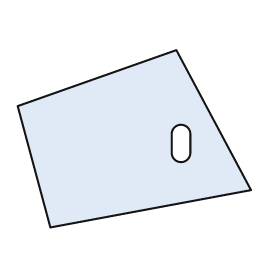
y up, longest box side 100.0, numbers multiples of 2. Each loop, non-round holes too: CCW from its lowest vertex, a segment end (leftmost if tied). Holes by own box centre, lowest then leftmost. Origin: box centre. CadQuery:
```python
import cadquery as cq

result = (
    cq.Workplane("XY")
    .moveTo(-36.0, -38.0)
    .lineTo(50.0, -22.0)
    .lineTo(18.0, 38.0)
    .lineTo(-50.0, 14.0)
    .close()
    .moveTo(16.0, -6.0)
    .threePointArc((20.0, -10.0), (24.0, -6.0))
    .lineTo(24.0, 2.0)
    .threePointArc((20.0, 6.0), (16.0, 2.0))
    .close()
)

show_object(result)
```